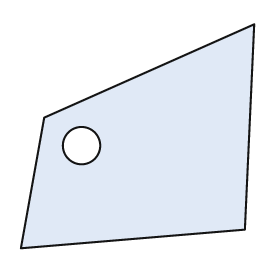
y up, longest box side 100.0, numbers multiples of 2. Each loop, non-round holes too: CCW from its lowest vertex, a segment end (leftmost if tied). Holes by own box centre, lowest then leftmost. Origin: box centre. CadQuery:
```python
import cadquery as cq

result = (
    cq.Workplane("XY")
    .moveTo(-50.0, -48.0)
    .lineTo(46.0, -40.0)
    .lineTo(50.0, 48.0)
    .lineTo(-40.0, 8.0)
    .close()
    .moveTo(-24.0, -4.0)
    .circle(8.0)
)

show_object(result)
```